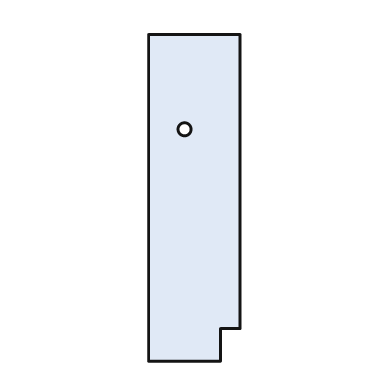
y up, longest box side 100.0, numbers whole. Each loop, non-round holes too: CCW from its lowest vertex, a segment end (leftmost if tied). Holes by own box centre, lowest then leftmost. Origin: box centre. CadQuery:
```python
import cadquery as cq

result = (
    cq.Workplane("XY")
    .moveTo(-14.0, -50.0)
    .lineTo(8.0, -50.0)
    .lineTo(8.0, -40.0)
    .lineTo(14.0, -40.0)
    .lineTo(14.0, 50.0)
    .lineTo(-14.0, 50.0)
    .close()
    .moveTo(-3.0, 21.0)
    .circle(2.0)
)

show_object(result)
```